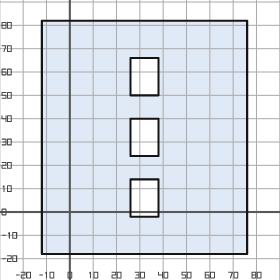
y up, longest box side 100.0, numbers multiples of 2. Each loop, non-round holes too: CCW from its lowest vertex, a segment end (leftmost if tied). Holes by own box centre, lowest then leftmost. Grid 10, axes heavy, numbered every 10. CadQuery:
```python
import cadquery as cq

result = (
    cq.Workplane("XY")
    .moveTo(-12.0, -18.0)
    .lineTo(76.0, -18.0)
    .lineTo(76.0, 82.0)
    .lineTo(-12.0, 82.0)
    .close()
    .moveTo(26.0, -2.0)
    .lineTo(38.0, -2.0)
    .lineTo(38.0, 14.0)
    .lineTo(26.0, 14.0)
    .close()
    .moveTo(26.0, 24.0)
    .lineTo(38.0, 24.0)
    .lineTo(38.0, 40.0)
    .lineTo(26.0, 40.0)
    .close()
    .moveTo(26.0, 50.0)
    .lineTo(38.0, 50.0)
    .lineTo(38.0, 66.0)
    .lineTo(26.0, 66.0)
    .close()
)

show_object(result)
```